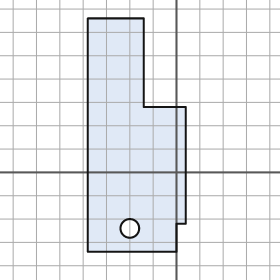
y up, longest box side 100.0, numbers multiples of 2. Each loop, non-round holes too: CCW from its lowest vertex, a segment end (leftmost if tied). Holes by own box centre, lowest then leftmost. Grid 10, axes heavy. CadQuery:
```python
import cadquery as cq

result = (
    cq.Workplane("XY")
    .moveTo(-38.0, -34.0)
    .lineTo(0.0, -34.0)
    .lineTo(0.0, -22.0)
    .lineTo(4.0, -22.0)
    .lineTo(4.0, 28.0)
    .lineTo(-14.0, 28.0)
    .lineTo(-14.0, 66.0)
    .lineTo(-38.0, 66.0)
    .close()
    .moveTo(-20.0, -24.0)
    .circle(4.0)
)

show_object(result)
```